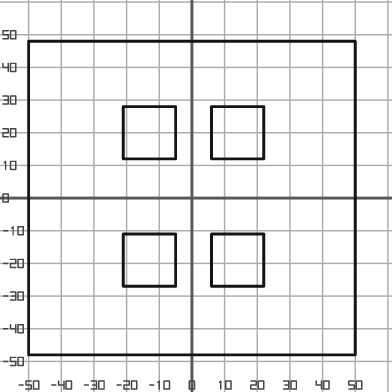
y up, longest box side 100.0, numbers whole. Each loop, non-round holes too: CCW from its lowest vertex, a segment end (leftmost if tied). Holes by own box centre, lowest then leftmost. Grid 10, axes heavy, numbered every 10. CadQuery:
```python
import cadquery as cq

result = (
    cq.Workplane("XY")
    .moveTo(-50.0, -48.0)
    .lineTo(50.0, -48.0)
    .lineTo(50.0, 48.0)
    .lineTo(-50.0, 48.0)
    .close()
    .moveTo(-21.0, -27.0)
    .lineTo(-5.0, -27.0)
    .lineTo(-5.0, -11.0)
    .lineTo(-21.0, -11.0)
    .close()
    .moveTo(6.0, -27.0)
    .lineTo(22.0, -27.0)
    .lineTo(22.0, -11.0)
    .lineTo(6.0, -11.0)
    .close()
    .moveTo(-21.0, 12.0)
    .lineTo(-5.0, 12.0)
    .lineTo(-5.0, 28.0)
    .lineTo(-21.0, 28.0)
    .close()
    .moveTo(6.0, 12.0)
    .lineTo(22.0, 12.0)
    .lineTo(22.0, 28.0)
    .lineTo(6.0, 28.0)
    .close()
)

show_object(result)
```